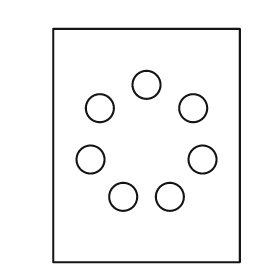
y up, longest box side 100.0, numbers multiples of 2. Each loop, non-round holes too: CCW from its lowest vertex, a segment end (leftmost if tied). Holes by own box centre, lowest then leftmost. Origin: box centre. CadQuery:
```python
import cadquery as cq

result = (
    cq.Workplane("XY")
    .moveTo(-40.0, -50.0)
    .lineTo(40.0, -50.0)
    .lineTo(40.0, 50.0)
    .lineTo(-40.0, 50.0)
    .close()
    .moveTo(-10.0, -22.0)
    .circle(6.0)
    .moveTo(10.0, -22.0)
    .circle(6.0)
    .moveTo(-24.0, -6.0)
    .circle(6.0)
    .moveTo(24.0, -6.0)
    .circle(6.0)
    .moveTo(-20.0, 16.0)
    .circle(6.0)
    .moveTo(20.0, 16.0)
    .circle(6.0)
    .moveTo(0.0, 26.0)
    .circle(6.0)
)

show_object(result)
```